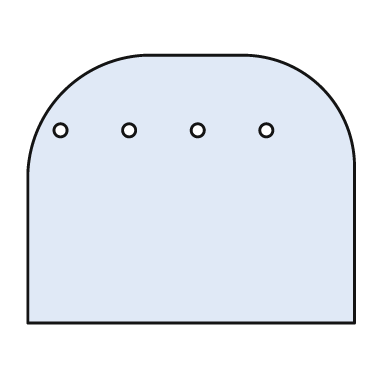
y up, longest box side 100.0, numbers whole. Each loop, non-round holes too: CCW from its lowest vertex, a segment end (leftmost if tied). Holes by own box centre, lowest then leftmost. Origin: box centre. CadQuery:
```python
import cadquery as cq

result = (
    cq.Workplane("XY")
    .moveTo(-50.0, -41.0)
    .lineTo(50.0, -41.0)
    .lineTo(50.0, 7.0)
    .threePointArc((40.0, 31.0), (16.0, 41.0))
    .lineTo(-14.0, 41.0)
    .threePointArc((-39.0, 30.0), (-50.0, 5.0))
    .close()
    .moveTo(-40.0, 18.0)
    .circle(2.0)
    .moveTo(-19.0, 18.0)
    .circle(2.0)
    .moveTo(2.0, 18.0)
    .circle(2.0)
    .moveTo(23.0, 18.0)
    .circle(2.0)
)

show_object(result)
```